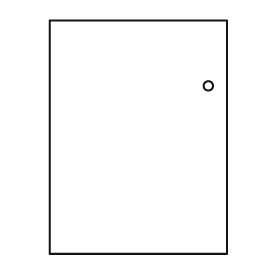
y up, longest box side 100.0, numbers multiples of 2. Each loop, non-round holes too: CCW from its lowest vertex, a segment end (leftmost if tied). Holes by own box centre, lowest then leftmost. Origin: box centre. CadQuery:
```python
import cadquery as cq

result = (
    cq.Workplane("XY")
    .moveTo(-38.0, -50.0)
    .lineTo(38.0, -50.0)
    .lineTo(38.0, 50.0)
    .lineTo(-38.0, 50.0)
    .close()
    .moveTo(30.0, 22.0)
    .circle(2.0)
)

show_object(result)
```